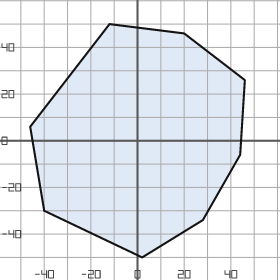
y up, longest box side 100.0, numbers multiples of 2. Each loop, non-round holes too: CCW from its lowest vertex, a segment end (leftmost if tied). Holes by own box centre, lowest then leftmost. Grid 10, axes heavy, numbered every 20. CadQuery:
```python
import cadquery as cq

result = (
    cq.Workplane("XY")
    .moveTo(2.0, -50.0)
    .lineTo(28.0, -34.0)
    .lineTo(44.0, -6.0)
    .lineTo(46.0, 26.0)
    .lineTo(20.0, 46.0)
    .lineTo(-12.0, 50.0)
    .lineTo(-46.0, 6.0)
    .lineTo(-40.0, -30.0)
    .close()
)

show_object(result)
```